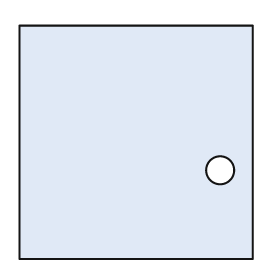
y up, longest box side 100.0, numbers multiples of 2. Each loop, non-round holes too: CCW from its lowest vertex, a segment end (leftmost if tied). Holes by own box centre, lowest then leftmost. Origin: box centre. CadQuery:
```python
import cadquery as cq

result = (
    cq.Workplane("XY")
    .moveTo(-50.0, -50.0)
    .lineTo(50.0, -50.0)
    .lineTo(50.0, 50.0)
    .lineTo(-50.0, 50.0)
    .close()
    .moveTo(36.0, -12.0)
    .circle(6.0)
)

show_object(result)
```